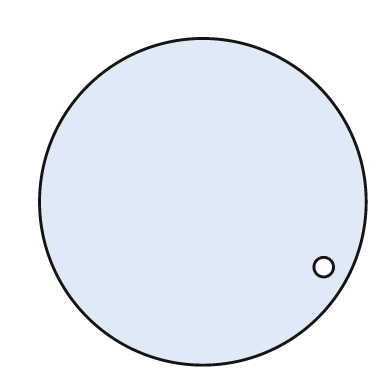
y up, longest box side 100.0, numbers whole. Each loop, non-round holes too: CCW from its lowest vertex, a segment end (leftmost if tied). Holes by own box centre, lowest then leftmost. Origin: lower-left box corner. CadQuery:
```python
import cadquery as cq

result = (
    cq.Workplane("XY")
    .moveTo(50.0, 50.0)
    .circle(50.0)
    .moveTo(87.0, 30.0)
    .circle(3.0)
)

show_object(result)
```